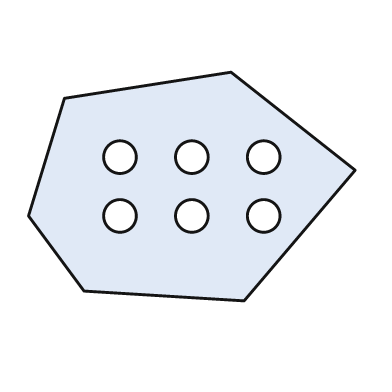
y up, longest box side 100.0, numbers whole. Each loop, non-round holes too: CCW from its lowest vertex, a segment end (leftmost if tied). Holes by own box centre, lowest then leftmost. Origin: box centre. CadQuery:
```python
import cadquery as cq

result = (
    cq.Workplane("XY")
    .moveTo(16.0, -35.0)
    .lineTo(50.0, 5.0)
    .lineTo(12.0, 35.0)
    .lineTo(-39.0, 27.0)
    .lineTo(-50.0, -9.0)
    .lineTo(-33.0, -32.0)
    .close()
    .moveTo(-22.0, -9.0)
    .circle(5.0)
    .moveTo(0.0, -9.0)
    .circle(5.0)
    .moveTo(22.0, -9.0)
    .circle(5.0)
    .moveTo(-22.0, 9.0)
    .circle(5.0)
    .moveTo(0.0, 9.0)
    .circle(5.0)
    .moveTo(22.0, 9.0)
    .circle(5.0)
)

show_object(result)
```